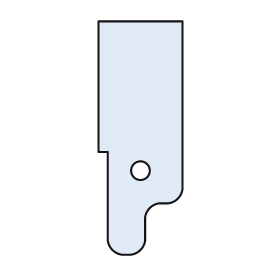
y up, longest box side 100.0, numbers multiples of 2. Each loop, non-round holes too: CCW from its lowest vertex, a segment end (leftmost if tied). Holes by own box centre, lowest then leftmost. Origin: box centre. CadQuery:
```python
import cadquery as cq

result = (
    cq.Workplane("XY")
    .moveTo(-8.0, -50.0)
    .lineTo(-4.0, -50.0)
    .threePointArc((0.0, -48.0), (2.0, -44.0))
    .lineTo(2.0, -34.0)
    .threePointArc((4.0, -30.0), (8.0, -28.0))
    .lineTo(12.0, -28.0)
    .threePointArc((16.0, -26.0), (18.0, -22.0))
    .lineTo(18.0, 50.0)
    .lineTo(-18.0, 50.0)
    .lineTo(-18.0, -6.0)
    .lineTo(-14.0, -6.0)
    .lineTo(-14.0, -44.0)
    .threePointArc((-12.0, -48.0), (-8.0, -50.0))
    .close()
    .moveTo(0.0, -14.0)
    .circle(4.0)
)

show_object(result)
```